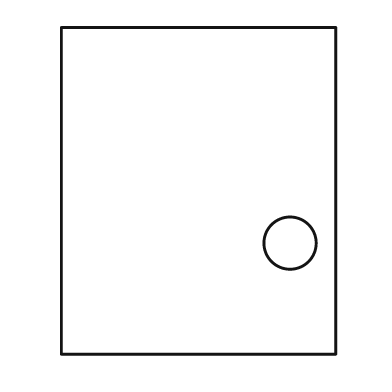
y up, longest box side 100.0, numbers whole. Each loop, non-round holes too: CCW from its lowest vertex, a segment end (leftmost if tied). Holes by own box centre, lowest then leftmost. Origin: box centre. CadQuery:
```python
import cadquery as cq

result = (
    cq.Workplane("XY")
    .moveTo(-42.0, -50.0)
    .lineTo(42.0, -50.0)
    .lineTo(42.0, 50.0)
    .lineTo(-42.0, 50.0)
    .close()
    .moveTo(28.0, -16.0)
    .circle(8.0)
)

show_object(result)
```